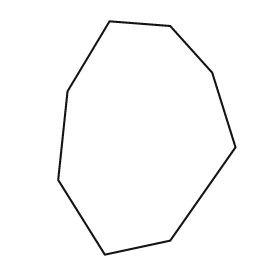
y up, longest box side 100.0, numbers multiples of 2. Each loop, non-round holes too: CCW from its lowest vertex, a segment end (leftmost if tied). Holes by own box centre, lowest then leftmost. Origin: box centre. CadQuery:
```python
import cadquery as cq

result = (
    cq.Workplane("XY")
    .moveTo(-18.0, -50.0)
    .lineTo(10.0, -44.0)
    .lineTo(38.0, -4.0)
    .lineTo(28.0, 28.0)
    .lineTo(10.0, 48.0)
    .lineTo(-16.0, 50.0)
    .lineTo(-34.0, 20.0)
    .lineTo(-38.0, -18.0)
    .close()
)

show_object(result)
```